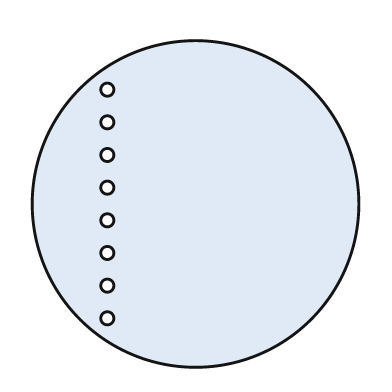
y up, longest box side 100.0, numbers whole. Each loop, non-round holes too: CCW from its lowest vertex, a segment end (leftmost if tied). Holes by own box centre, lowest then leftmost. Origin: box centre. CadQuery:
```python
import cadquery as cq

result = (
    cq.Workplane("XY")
    .moveTo(0.0, 0.0)
    .circle(50.0)
    .moveTo(-27.0, -35.0)
    .circle(2.0)
    .moveTo(-27.0, -25.0)
    .circle(2.0)
    .moveTo(-27.0, -15.0)
    .circle(2.0)
    .moveTo(-27.0, -5.0)
    .circle(2.0)
    .moveTo(-27.0, 5.0)
    .circle(2.0)
    .moveTo(-27.0, 15.0)
    .circle(2.0)
    .moveTo(-27.0, 25.0)
    .circle(2.0)
    .moveTo(-27.0, 35.0)
    .circle(2.0)
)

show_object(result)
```